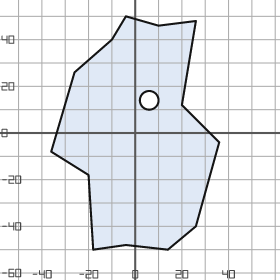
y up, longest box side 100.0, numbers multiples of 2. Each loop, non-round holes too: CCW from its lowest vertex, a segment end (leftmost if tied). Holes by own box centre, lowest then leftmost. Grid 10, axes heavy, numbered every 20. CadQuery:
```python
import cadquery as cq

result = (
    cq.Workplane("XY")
    .moveTo(-18.0, -50.0)
    .lineTo(-4.0, -48.0)
    .lineTo(14.0, -50.0)
    .lineTo(26.0, -40.0)
    .lineTo(36.0, -4.0)
    .lineTo(20.0, 12.0)
    .lineTo(26.0, 48.0)
    .lineTo(10.0, 46.0)
    .lineTo(-4.0, 50.0)
    .lineTo(-10.0, 40.0)
    .lineTo(-26.0, 26.0)
    .lineTo(-36.0, -8.0)
    .lineTo(-20.0, -18.0)
    .close()
    .moveTo(6.0, 14.0)
    .circle(4.0)
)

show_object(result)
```